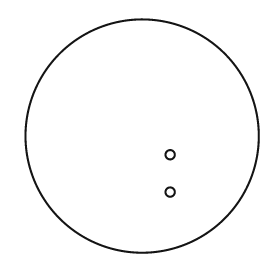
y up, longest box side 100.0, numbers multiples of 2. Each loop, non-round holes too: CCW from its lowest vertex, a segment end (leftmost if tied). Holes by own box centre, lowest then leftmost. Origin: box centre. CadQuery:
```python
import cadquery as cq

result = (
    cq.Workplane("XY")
    .moveTo(0.0, 0.0)
    .circle(50.0)
    .moveTo(12.0, -24.0)
    .circle(2.0)
    .moveTo(12.0, -8.0)
    .circle(2.0)
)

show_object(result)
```